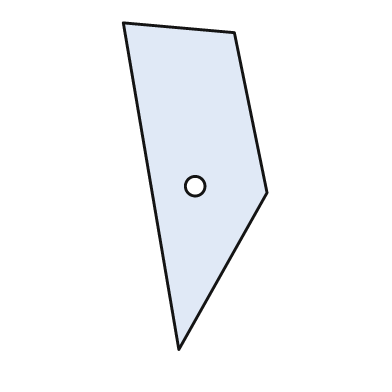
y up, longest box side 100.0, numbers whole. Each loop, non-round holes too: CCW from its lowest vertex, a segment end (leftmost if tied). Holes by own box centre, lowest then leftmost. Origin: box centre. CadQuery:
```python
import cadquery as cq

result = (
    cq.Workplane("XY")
    .moveTo(-5.0, -50.0)
    .lineTo(22.0, -2.0)
    .lineTo(12.0, 47.0)
    .lineTo(-22.0, 50.0)
    .close()
    .moveTo(0.0, 0.0)
    .circle(3.0)
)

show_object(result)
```